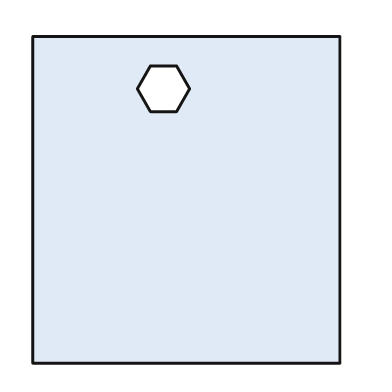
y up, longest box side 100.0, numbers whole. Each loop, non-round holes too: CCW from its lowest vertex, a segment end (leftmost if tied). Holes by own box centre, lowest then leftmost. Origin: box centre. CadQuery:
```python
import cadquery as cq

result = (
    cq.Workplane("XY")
    .moveTo(-47.0, -50.0)
    .lineTo(47.0, -50.0)
    .lineTo(47.0, 50.0)
    .lineTo(-47.0, 50.0)
    .close()
    .moveTo(-11.0, 27.0)
    .lineTo(-3.0, 27.0)
    .lineTo(1.0, 34.0)
    .lineTo(-3.0, 41.0)
    .lineTo(-11.0, 41.0)
    .lineTo(-15.0, 34.0)
    .close()
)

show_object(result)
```